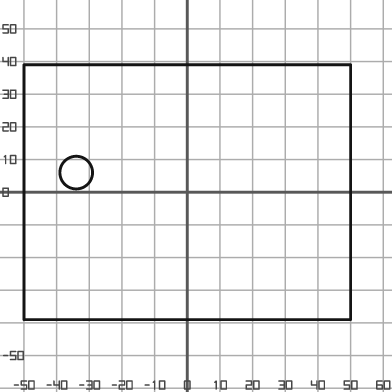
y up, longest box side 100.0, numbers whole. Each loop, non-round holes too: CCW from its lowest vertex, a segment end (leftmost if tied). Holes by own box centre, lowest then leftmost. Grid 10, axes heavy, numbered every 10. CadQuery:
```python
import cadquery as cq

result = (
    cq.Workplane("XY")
    .moveTo(-50.0, -39.0)
    .lineTo(50.0, -39.0)
    .lineTo(50.0, 39.0)
    .lineTo(-50.0, 39.0)
    .close()
    .moveTo(-34.0, 6.0)
    .circle(5.0)
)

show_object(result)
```